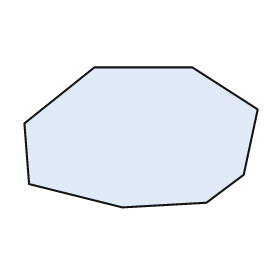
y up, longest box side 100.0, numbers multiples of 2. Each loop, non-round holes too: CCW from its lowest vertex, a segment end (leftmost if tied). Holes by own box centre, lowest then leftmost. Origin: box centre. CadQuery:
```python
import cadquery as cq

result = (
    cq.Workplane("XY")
    .moveTo(-8.0, -30.0)
    .lineTo(28.0, -28.0)
    .lineTo(44.0, -16.0)
    .lineTo(50.0, 12.0)
    .lineTo(22.0, 30.0)
    .lineTo(-20.0, 30.0)
    .lineTo(-50.0, 6.0)
    .lineTo(-48.0, -20.0)
    .close()
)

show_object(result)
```